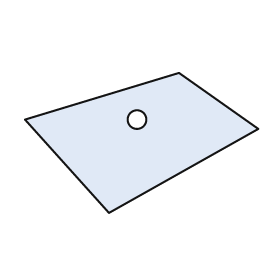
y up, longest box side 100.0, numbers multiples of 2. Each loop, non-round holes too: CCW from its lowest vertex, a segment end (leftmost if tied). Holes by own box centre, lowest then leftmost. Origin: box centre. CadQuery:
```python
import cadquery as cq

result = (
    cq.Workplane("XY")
    .moveTo(-14.0, -30.0)
    .lineTo(50.0, 6.0)
    .lineTo(16.0, 30.0)
    .lineTo(-50.0, 10.0)
    .close()
    .moveTo(-2.0, 10.0)
    .circle(4.0)
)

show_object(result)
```